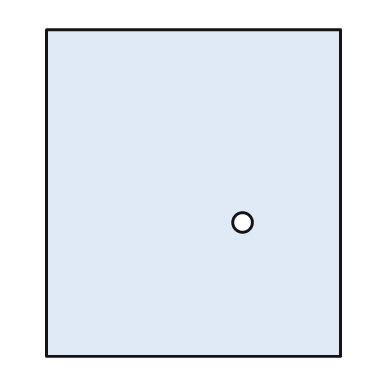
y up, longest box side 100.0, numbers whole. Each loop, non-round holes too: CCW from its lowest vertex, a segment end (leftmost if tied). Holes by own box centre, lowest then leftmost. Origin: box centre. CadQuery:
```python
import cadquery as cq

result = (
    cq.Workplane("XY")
    .moveTo(-45.0, -50.0)
    .lineTo(45.0, -50.0)
    .lineTo(45.0, 50.0)
    .lineTo(-45.0, 50.0)
    .close()
    .moveTo(15.0, -9.0)
    .circle(3.0)
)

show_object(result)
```